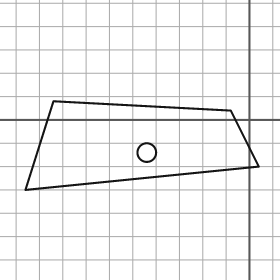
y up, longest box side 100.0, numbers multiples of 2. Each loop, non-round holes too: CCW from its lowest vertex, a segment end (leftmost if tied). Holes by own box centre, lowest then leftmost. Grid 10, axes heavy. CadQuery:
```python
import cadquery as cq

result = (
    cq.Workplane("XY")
    .moveTo(-96.0, -30.0)
    .lineTo(4.0, -20.0)
    .lineTo(-8.0, 4.0)
    .lineTo(-84.0, 8.0)
    .close()
    .moveTo(-44.0, -14.0)
    .circle(4.0)
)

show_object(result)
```